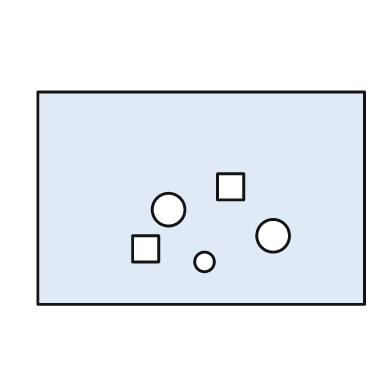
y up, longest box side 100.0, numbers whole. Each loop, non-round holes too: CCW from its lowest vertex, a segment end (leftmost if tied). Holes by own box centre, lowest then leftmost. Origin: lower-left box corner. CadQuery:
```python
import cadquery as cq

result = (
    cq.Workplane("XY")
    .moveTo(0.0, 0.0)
    .lineTo(100.0, 0.0)
    .lineTo(100.0, 65.0)
    .lineTo(0.0, 65.0)
    .close()
    .moveTo(51.0, 13.0)
    .circle(3.0)
    .moveTo(29.0, 13.0)
    .lineTo(37.0, 13.0)
    .lineTo(37.0, 21.0)
    .lineTo(29.0, 21.0)
    .close()
    .moveTo(72.0, 21.0)
    .circle(5.0)
    .moveTo(40.0, 29.0)
    .circle(5.0)
    .moveTo(55.0, 32.0)
    .lineTo(63.0, 32.0)
    .lineTo(63.0, 40.0)
    .lineTo(55.0, 40.0)
    .close()
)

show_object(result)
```